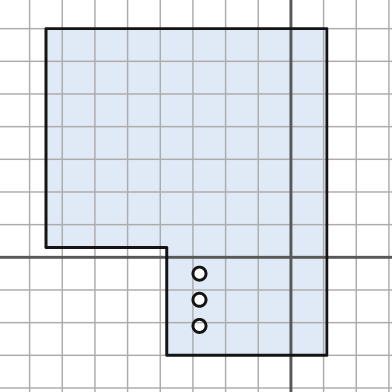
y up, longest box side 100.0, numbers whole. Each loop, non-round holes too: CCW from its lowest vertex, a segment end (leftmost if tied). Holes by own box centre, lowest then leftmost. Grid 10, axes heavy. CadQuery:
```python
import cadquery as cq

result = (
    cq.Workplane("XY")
    .moveTo(-38.0, -30.0)
    .lineTo(11.0, -30.0)
    .lineTo(11.0, 70.0)
    .lineTo(-75.0, 70.0)
    .lineTo(-75.0, 3.0)
    .lineTo(-38.0, 3.0)
    .close()
    .moveTo(-28.0, -21.0)
    .circle(2.0)
    .moveTo(-28.0, -13.0)
    .circle(2.0)
    .moveTo(-28.0, -5.0)
    .circle(2.0)
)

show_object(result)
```